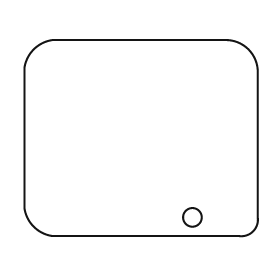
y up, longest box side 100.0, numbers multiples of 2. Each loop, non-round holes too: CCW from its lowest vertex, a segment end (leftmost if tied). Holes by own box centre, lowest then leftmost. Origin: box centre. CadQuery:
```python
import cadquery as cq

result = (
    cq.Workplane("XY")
    .moveTo(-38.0, -42.0)
    .lineTo(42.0, -42.0)
    .threePointArc((48.0, -40.0), (50.0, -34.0))
    .lineTo(50.0, 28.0)
    .threePointArc((46.0, 38.0), (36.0, 42.0))
    .lineTo(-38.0, 42.0)
    .threePointArc((-46.0, 38.0), (-50.0, 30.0))
    .lineTo(-50.0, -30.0)
    .threePointArc((-46.0, -38.0), (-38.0, -42.0))
    .close()
    .moveTo(22.0, -34.0)
    .circle(4.0)
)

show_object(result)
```